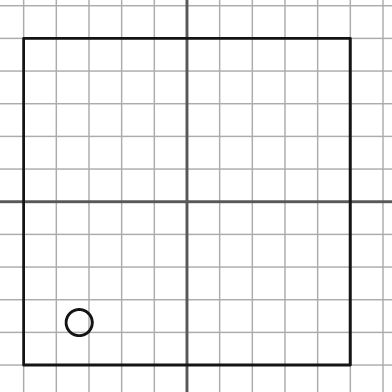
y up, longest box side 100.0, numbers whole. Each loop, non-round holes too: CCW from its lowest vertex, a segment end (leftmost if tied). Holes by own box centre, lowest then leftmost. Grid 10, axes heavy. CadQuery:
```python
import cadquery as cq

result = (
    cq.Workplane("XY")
    .moveTo(-50.0, -50.0)
    .lineTo(50.0, -50.0)
    .lineTo(50.0, 50.0)
    .lineTo(-50.0, 50.0)
    .close()
    .moveTo(-33.0, -37.0)
    .circle(4.0)
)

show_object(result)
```